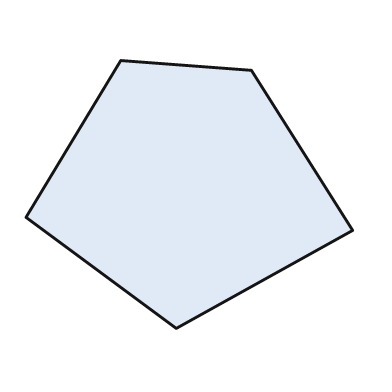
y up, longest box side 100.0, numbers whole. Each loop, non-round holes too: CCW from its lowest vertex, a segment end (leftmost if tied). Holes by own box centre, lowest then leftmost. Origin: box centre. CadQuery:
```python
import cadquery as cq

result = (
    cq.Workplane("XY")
    .moveTo(-4.0, -41.0)
    .lineTo(50.0, -11.0)
    .lineTo(19.0, 38.0)
    .lineTo(-21.0, 41.0)
    .lineTo(-50.0, -7.0)
    .close()
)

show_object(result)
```